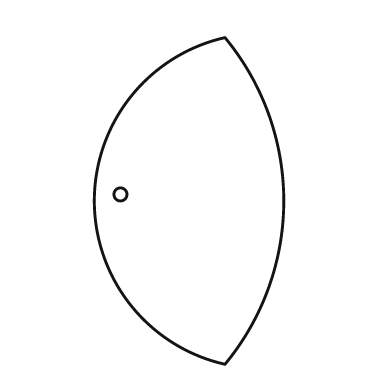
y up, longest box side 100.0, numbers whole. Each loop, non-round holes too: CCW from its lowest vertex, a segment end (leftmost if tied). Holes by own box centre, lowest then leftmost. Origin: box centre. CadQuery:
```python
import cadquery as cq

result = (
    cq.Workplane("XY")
    .moveTo(11.0, -50.0)
    .threePointArc((29.0, 0.0), (11.0, 50.0))
    .threePointArc((-29.0, 0.0), (11.0, -50.0))
    .close()
    .moveTo(-21.0, 2.0)
    .circle(2.0)
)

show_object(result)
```